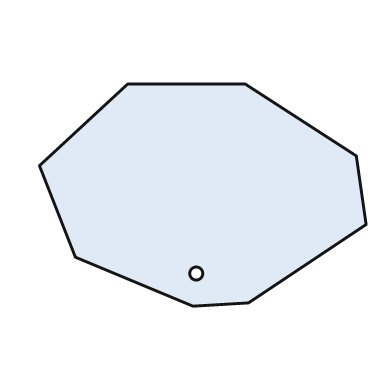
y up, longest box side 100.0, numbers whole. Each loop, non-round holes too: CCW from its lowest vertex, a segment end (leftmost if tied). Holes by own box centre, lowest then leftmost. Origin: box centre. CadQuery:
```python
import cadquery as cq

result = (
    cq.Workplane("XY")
    .moveTo(-3.0, -34.0)
    .lineTo(14.0, -33.0)
    .lineTo(50.0, -9.0)
    .lineTo(47.0, 12.0)
    .lineTo(13.0, 34.0)
    .lineTo(-23.0, 34.0)
    .lineTo(-50.0, 9.0)
    .lineTo(-39.0, -19.0)
    .close()
    .moveTo(-2.0, -24.0)
    .circle(2.0)
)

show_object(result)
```